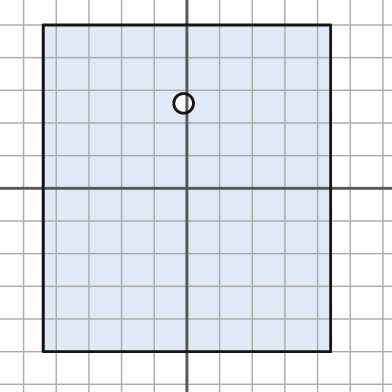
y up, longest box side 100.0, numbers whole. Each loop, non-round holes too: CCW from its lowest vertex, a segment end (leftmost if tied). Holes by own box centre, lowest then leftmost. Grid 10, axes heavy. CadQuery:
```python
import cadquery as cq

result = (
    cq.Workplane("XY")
    .moveTo(-44.0, -50.0)
    .lineTo(44.0, -50.0)
    .lineTo(44.0, 50.0)
    .lineTo(-44.0, 50.0)
    .close()
    .moveTo(-1.0, 26.0)
    .circle(3.0)
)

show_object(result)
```